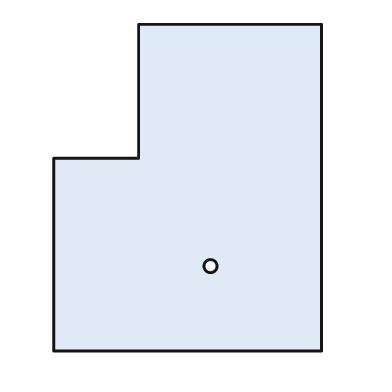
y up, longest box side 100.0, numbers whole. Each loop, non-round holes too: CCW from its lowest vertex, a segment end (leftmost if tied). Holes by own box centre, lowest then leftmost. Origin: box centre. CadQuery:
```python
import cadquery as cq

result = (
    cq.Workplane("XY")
    .moveTo(-41.0, -50.0)
    .lineTo(41.0, -50.0)
    .lineTo(41.0, 50.0)
    .lineTo(-15.0, 50.0)
    .lineTo(-15.0, 9.0)
    .lineTo(-41.0, 9.0)
    .close()
    .moveTo(7.0, -24.0)
    .circle(2.0)
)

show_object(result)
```